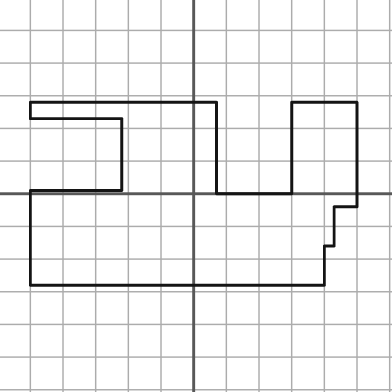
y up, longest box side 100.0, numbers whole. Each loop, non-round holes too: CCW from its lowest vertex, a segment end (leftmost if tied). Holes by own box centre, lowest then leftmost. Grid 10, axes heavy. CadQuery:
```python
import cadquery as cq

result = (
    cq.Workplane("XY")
    .moveTo(-50.0, -28.0)
    .lineTo(40.0, -28.0)
    .lineTo(40.0, -16.0)
    .lineTo(43.0, -16.0)
    .lineTo(43.0, -4.0)
    .lineTo(50.0, -4.0)
    .lineTo(50.0, 28.0)
    .lineTo(30.0, 28.0)
    .lineTo(30.0, 0.0)
    .lineTo(7.0, 0.0)
    .lineTo(7.0, 28.0)
    .lineTo(-50.0, 28.0)
    .lineTo(-50.0, 23.0)
    .lineTo(-22.0, 23.0)
    .lineTo(-22.0, 1.0)
    .lineTo(-50.0, 1.0)
    .close()
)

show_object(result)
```